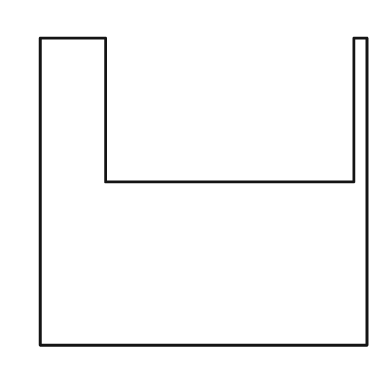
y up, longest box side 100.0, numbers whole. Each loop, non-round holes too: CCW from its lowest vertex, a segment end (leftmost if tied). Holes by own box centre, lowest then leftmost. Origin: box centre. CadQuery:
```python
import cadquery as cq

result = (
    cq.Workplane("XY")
    .moveTo(-50.0, -47.0)
    .lineTo(50.0, -47.0)
    .lineTo(50.0, 47.0)
    .lineTo(46.0, 47.0)
    .lineTo(46.0, 3.0)
    .lineTo(-30.0, 3.0)
    .lineTo(-30.0, 47.0)
    .lineTo(-50.0, 47.0)
    .close()
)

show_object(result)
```